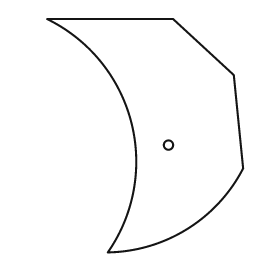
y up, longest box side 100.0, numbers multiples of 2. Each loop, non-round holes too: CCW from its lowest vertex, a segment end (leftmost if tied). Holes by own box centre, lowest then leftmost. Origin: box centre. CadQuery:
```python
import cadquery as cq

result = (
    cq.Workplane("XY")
    .moveTo(-16.0, -50.0)
    .threePointArc((18.0, -40.0), (42.0, -14.0))
    .lineTo(38.0, 26.0)
    .lineTo(12.0, 50.0)
    .lineTo(-42.0, 50.0)
    .threePointArc((-6.0, 6.0), (-16.0, -50.0))
    .close()
    .moveTo(10.0, -4.0)
    .circle(2.0)
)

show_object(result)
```